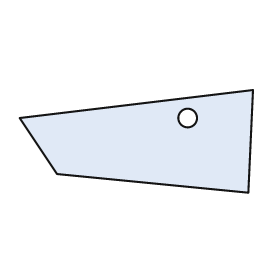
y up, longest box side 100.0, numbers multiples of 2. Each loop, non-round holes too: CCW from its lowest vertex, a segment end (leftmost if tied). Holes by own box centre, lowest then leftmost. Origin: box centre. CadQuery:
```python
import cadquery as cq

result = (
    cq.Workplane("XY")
    .moveTo(48.0, -22.0)
    .lineTo(50.0, 22.0)
    .lineTo(-50.0, 10.0)
    .lineTo(-34.0, -14.0)
    .close()
    .moveTo(22.0, 10.0)
    .circle(4.0)
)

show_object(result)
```